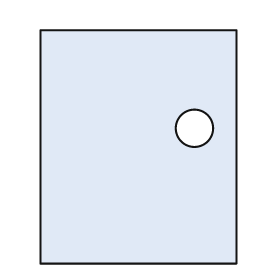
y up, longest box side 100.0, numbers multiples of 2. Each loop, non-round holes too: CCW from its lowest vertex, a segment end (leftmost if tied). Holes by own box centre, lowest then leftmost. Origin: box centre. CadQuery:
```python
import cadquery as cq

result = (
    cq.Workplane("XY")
    .moveTo(-42.0, -50.0)
    .lineTo(42.0, -50.0)
    .lineTo(42.0, 50.0)
    .lineTo(-42.0, 50.0)
    .close()
    .moveTo(24.0, 8.0)
    .circle(8.0)
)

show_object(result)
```